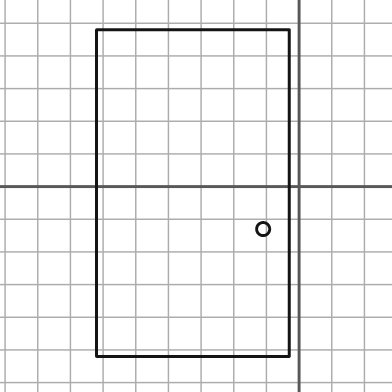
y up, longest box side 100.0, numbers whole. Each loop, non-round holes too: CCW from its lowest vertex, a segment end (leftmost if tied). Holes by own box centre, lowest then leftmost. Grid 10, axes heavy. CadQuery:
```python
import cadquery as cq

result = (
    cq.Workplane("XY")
    .moveTo(-62.0, -52.0)
    .lineTo(-3.0, -52.0)
    .lineTo(-3.0, 48.0)
    .lineTo(-62.0, 48.0)
    .close()
    .moveTo(-11.0, -13.0)
    .circle(2.0)
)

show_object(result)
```